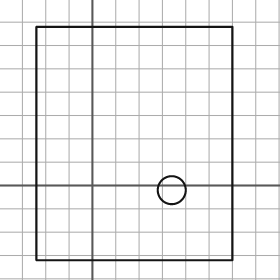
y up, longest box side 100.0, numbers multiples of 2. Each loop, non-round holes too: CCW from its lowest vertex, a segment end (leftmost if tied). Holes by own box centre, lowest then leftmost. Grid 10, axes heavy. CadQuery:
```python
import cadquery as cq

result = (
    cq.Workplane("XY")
    .moveTo(-24.0, -32.0)
    .lineTo(60.0, -32.0)
    .lineTo(60.0, 68.0)
    .lineTo(-24.0, 68.0)
    .close()
    .moveTo(34.0, -2.0)
    .circle(6.0)
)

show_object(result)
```